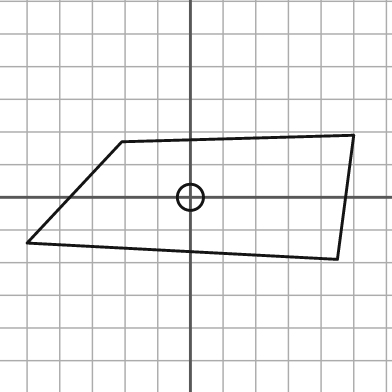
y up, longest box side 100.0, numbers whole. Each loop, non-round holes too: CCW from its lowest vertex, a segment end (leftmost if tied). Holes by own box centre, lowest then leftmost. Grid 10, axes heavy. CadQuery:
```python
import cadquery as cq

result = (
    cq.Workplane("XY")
    .moveTo(45.0, -19.0)
    .lineTo(50.0, 19.0)
    .lineTo(-21.0, 17.0)
    .lineTo(-50.0, -14.0)
    .close()
    .moveTo(0.0, 0.0)
    .circle(4.0)
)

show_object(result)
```